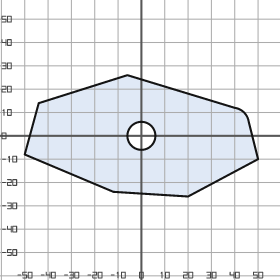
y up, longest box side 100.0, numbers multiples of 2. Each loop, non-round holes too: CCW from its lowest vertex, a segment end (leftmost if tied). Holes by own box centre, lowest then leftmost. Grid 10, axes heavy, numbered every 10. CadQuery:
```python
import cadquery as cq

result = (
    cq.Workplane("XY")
    .moveTo(20.0, -26.0)
    .lineTo(50.0, -10.0)
    .lineTo(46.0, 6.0)
    .threePointArc((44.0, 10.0), (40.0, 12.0))
    .lineTo(-6.0, 26.0)
    .lineTo(-44.0, 14.0)
    .lineTo(-50.0, -8.0)
    .lineTo(-12.0, -24.0)
    .close()
    .moveTo(0.0, 0.0)
    .circle(6.0)
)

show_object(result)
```